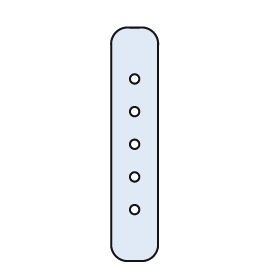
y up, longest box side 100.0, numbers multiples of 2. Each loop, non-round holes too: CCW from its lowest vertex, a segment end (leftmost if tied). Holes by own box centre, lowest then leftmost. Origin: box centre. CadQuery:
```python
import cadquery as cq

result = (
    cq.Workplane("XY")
    .moveTo(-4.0, -50.0)
    .lineTo(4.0, -50.0)
    .threePointArc((8.0, -48.0), (10.0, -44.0))
    .lineTo(10.0, 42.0)
    .threePointArc((8.0, 48.0), (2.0, 50.0))
    .lineTo(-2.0, 50.0)
    .threePointArc((-8.0, 48.0), (-10.0, 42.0))
    .lineTo(-10.0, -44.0)
    .threePointArc((-8.0, -48.0), (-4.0, -50.0))
    .close()
    .moveTo(0.0, -28.0)
    .circle(2.0)
    .moveTo(0.0, -14.0)
    .circle(2.0)
    .moveTo(0.0, 0.0)
    .circle(2.0)
    .moveTo(0.0, 14.0)
    .circle(2.0)
    .moveTo(0.0, 28.0)
    .circle(2.0)
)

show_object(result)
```